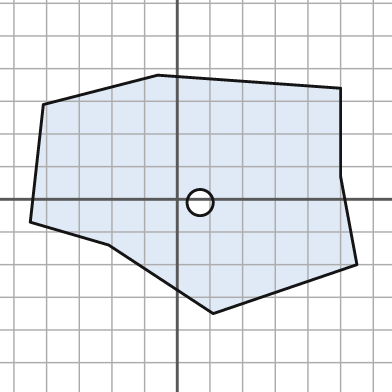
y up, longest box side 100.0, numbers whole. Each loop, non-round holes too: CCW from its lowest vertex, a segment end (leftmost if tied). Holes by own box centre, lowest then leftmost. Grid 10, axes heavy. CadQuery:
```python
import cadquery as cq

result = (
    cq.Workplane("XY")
    .moveTo(11.0, -35.0)
    .lineTo(55.0, -20.0)
    .lineTo(50.0, 7.0)
    .lineTo(50.0, 34.0)
    .lineTo(-6.0, 38.0)
    .lineTo(-41.0, 29.0)
    .lineTo(-45.0, -7.0)
    .lineTo(-21.0, -14.0)
    .close()
    .moveTo(7.0, -1.0)
    .circle(4.0)
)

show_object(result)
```